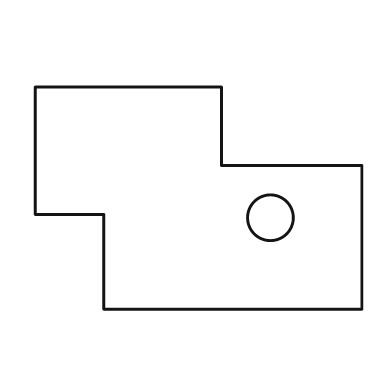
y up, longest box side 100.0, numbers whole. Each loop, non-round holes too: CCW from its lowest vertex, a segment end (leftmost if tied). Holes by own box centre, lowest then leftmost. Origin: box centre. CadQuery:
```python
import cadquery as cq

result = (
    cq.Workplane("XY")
    .moveTo(-29.0, -34.0)
    .lineTo(50.0, -34.0)
    .lineTo(50.0, 10.0)
    .lineTo(7.0, 10.0)
    .lineTo(7.0, 34.0)
    .lineTo(-50.0, 34.0)
    .lineTo(-50.0, -5.0)
    .lineTo(-29.0, -5.0)
    .close()
    .moveTo(22.0, -6.0)
    .circle(7.0)
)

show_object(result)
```